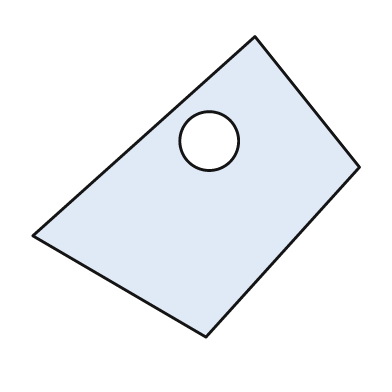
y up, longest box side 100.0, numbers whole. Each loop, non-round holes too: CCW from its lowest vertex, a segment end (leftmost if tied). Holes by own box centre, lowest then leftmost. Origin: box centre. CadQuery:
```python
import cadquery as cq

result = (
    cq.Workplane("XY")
    .moveTo(3.0, -46.0)
    .lineTo(50.0, 6.0)
    .lineTo(18.0, 46.0)
    .lineTo(-50.0, -15.0)
    .close()
    .moveTo(4.0, 14.0)
    .circle(9.0)
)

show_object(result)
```